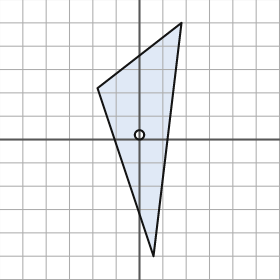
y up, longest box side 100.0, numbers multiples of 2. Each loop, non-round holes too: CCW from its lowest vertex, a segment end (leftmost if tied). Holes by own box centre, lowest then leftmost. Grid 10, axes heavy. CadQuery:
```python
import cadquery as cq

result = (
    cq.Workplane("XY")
    .moveTo(6.0, -50.0)
    .lineTo(18.0, 50.0)
    .lineTo(-18.0, 22.0)
    .close()
    .moveTo(0.0, 2.0)
    .circle(2.0)
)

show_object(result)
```